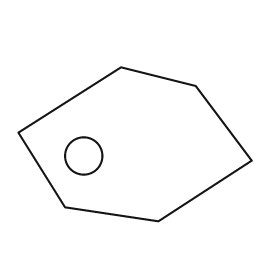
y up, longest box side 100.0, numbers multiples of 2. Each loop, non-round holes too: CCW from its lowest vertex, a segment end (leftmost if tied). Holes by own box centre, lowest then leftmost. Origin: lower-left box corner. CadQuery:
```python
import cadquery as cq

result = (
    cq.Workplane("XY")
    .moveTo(60.0, 0.0)
    .lineTo(100.0, 26.0)
    .lineTo(76.0, 58.0)
    .lineTo(44.0, 66.0)
    .lineTo(0.0, 38.0)
    .lineTo(20.0, 6.0)
    .close()
    .moveTo(28.0, 28.0)
    .circle(8.0)
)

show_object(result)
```